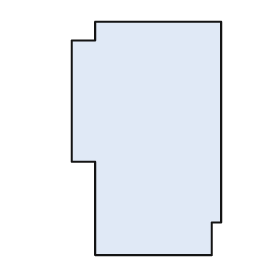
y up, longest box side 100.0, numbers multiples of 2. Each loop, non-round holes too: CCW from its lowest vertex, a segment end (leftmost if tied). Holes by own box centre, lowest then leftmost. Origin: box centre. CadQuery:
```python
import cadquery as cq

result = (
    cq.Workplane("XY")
    .moveTo(-22.0, -50.0)
    .lineTo(28.0, -50.0)
    .lineTo(28.0, -36.0)
    .lineTo(32.0, -36.0)
    .lineTo(32.0, 50.0)
    .lineTo(-22.0, 50.0)
    .lineTo(-22.0, 42.0)
    .lineTo(-32.0, 42.0)
    .lineTo(-32.0, -10.0)
    .lineTo(-22.0, -10.0)
    .close()
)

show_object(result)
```